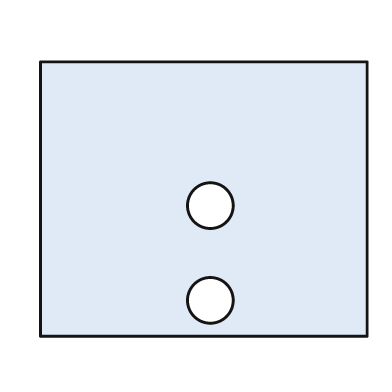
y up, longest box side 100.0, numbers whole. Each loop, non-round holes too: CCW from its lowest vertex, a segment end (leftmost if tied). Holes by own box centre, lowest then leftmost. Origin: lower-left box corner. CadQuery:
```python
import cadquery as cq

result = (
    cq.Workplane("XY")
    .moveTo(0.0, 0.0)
    .lineTo(100.0, 0.0)
    .lineTo(100.0, 84.0)
    .lineTo(0.0, 84.0)
    .close()
    .moveTo(52.0, 11.0)
    .circle(7.0)
    .moveTo(52.0, 40.0)
    .circle(7.0)
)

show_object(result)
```